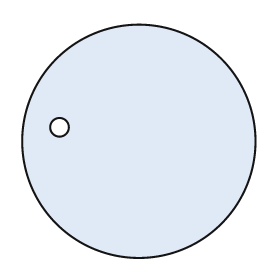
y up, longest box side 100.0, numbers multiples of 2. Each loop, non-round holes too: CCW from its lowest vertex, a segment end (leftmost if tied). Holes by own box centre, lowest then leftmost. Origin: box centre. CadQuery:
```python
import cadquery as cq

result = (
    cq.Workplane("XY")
    .moveTo(0.0, 0.0)
    .circle(50.0)
    .moveTo(-34.0, 6.0)
    .circle(4.0)
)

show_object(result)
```